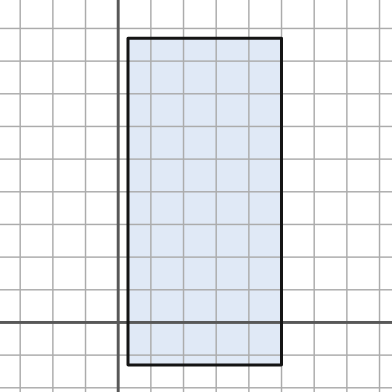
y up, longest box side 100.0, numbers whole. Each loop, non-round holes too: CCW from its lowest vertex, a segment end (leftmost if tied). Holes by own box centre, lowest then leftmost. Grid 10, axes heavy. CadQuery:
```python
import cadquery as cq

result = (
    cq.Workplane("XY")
    .moveTo(3.0, -13.0)
    .lineTo(50.0, -13.0)
    .lineTo(50.0, 87.0)
    .lineTo(3.0, 87.0)
    .close()
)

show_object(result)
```